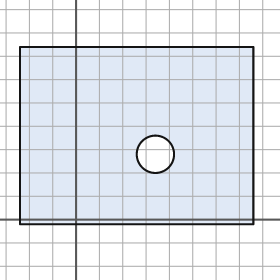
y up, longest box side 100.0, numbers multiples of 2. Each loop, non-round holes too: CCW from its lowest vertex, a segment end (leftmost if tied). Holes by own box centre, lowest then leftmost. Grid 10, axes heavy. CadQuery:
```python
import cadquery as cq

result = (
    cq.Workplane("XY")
    .moveTo(-24.0, -2.0)
    .lineTo(76.0, -2.0)
    .lineTo(76.0, 74.0)
    .lineTo(-24.0, 74.0)
    .close()
    .moveTo(34.0, 28.0)
    .circle(8.0)
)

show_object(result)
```